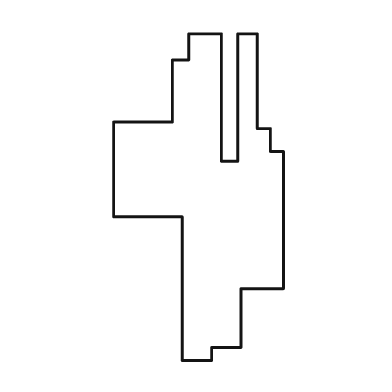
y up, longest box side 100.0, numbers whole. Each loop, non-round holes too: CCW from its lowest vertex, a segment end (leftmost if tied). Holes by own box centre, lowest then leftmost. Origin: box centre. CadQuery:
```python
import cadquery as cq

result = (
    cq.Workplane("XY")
    .moveTo(-5.0, -50.0)
    .lineTo(4.0, -50.0)
    .lineTo(4.0, -46.0)
    .lineTo(13.0, -46.0)
    .lineTo(13.0, -28.0)
    .lineTo(26.0, -28.0)
    .lineTo(26.0, 14.0)
    .lineTo(22.0, 14.0)
    .lineTo(22.0, 21.0)
    .lineTo(18.0, 21.0)
    .lineTo(18.0, 50.0)
    .lineTo(12.0, 50.0)
    .lineTo(12.0, 11.0)
    .lineTo(7.0, 11.0)
    .lineTo(7.0, 50.0)
    .lineTo(-3.0, 50.0)
    .lineTo(-3.0, 42.0)
    .lineTo(-8.0, 42.0)
    .lineTo(-8.0, 23.0)
    .lineTo(-26.0, 23.0)
    .lineTo(-26.0, -6.0)
    .lineTo(-5.0, -6.0)
    .close()
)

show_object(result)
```